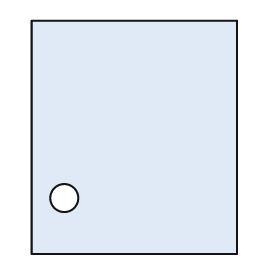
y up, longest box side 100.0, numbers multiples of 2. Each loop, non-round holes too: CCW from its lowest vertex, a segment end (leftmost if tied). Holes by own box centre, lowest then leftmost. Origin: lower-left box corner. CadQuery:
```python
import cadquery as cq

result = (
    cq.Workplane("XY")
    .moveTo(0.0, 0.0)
    .lineTo(88.0, 0.0)
    .lineTo(88.0, 100.0)
    .lineTo(0.0, 100.0)
    .close()
    .moveTo(14.0, 24.0)
    .circle(6.0)
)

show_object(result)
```